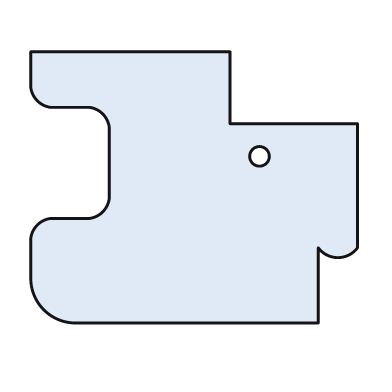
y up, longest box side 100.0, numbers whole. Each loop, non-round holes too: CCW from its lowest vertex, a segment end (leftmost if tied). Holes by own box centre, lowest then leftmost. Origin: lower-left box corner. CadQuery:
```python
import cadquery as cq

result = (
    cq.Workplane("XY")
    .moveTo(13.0, 0.0)
    .lineTo(88.0, 0.0)
    .lineTo(88.0, 23.0)
    .threePointArc((94.0, 20.0), (100.0, 23.0))
    .lineTo(100.0, 61.0)
    .lineTo(61.0, 61.0)
    .lineTo(61.0, 83.0)
    .lineTo(0.0, 83.0)
    .lineTo(0.0, 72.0)
    .threePointArc((2.0, 68.0), (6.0, 66.0))
    .lineTo(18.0, 66.0)
    .threePointArc((22.0, 64.0), (24.0, 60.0))
    .lineTo(24.0, 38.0)
    .threePointArc((22.0, 34.0), (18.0, 32.0))
    .lineTo(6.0, 32.0)
    .threePointArc((2.0, 30.0), (0.0, 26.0))
    .lineTo(0.0, 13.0)
    .threePointArc((4.0, 4.0), (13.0, 0.0))
    .close()
    .moveTo(70.0, 51.0)
    .circle(3.0)
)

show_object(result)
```